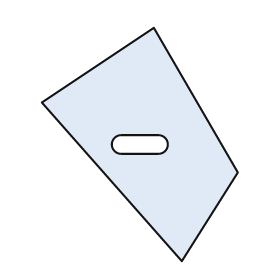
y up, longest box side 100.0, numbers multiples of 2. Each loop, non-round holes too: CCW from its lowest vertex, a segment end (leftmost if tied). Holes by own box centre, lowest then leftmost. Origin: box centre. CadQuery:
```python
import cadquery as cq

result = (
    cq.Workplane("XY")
    .moveTo(18.0, -50.0)
    .lineTo(42.0, -12.0)
    .lineTo(6.0, 50.0)
    .lineTo(-42.0, 18.0)
    .close()
    .moveTo(-8.0, -4.0)
    .lineTo(8.0, -4.0)
    .threePointArc((12.0, 0.0), (8.0, 4.0))
    .lineTo(-8.0, 4.0)
    .threePointArc((-12.0, 0.0), (-8.0, -4.0))
    .close()
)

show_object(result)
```